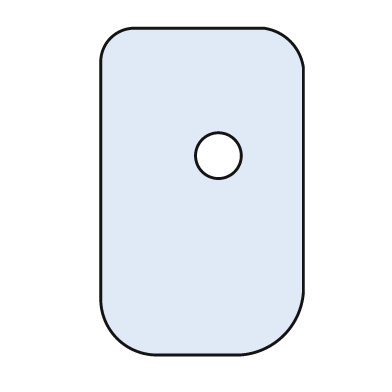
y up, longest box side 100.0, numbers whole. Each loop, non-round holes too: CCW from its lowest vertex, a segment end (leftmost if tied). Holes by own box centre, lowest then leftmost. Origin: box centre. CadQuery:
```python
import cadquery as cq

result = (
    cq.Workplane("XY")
    .moveTo(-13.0, -50.0)
    .lineTo(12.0, -50.0)
    .threePointArc((25.0, -44.0), (31.0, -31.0))
    .lineTo(31.0, 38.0)
    .threePointArc((27.0, 46.0), (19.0, 50.0))
    .lineTo(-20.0, 50.0)
    .threePointArc((-28.0, 47.0), (-31.0, 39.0))
    .lineTo(-31.0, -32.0)
    .threePointArc((-26.0, -45.0), (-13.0, -50.0))
    .close()
    .moveTo(5.0, 11.0)
    .circle(7.0)
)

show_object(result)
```